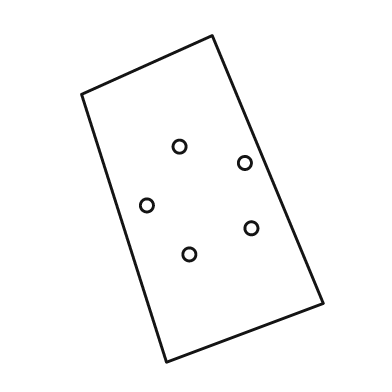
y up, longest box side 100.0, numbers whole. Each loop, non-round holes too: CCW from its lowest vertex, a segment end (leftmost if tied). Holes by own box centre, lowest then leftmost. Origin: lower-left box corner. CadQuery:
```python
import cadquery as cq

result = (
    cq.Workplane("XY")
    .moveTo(26.0, 0.0)
    .lineTo(74.0, 18.0)
    .lineTo(40.0, 100.0)
    .lineTo(0.0, 82.0)
    .close()
    .moveTo(33.0, 33.0)
    .circle(2.0)
    .moveTo(52.0, 41.0)
    .circle(2.0)
    .moveTo(20.0, 48.0)
    .circle(2.0)
    .moveTo(50.0, 61.0)
    .circle(2.0)
    .moveTo(30.0, 66.0)
    .circle(2.0)
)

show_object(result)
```